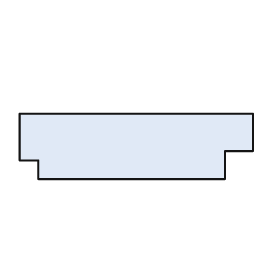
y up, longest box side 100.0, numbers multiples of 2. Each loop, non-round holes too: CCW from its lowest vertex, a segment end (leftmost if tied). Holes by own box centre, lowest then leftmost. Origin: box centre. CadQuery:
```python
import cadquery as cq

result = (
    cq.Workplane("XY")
    .moveTo(-42.0, -14.0)
    .lineTo(38.0, -14.0)
    .lineTo(38.0, -2.0)
    .lineTo(50.0, -2.0)
    .lineTo(50.0, 14.0)
    .lineTo(-50.0, 14.0)
    .lineTo(-50.0, -6.0)
    .lineTo(-42.0, -6.0)
    .close()
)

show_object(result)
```